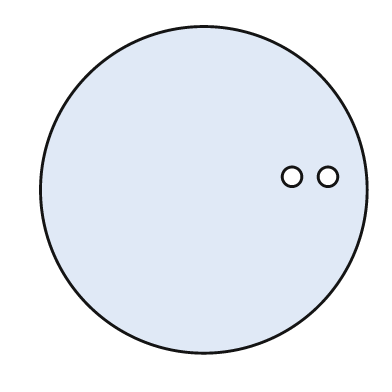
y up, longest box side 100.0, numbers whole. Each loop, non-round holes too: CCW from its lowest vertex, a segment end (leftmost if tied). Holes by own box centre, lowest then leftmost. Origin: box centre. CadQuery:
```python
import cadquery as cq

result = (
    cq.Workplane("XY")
    .moveTo(0.0, 0.0)
    .circle(50.0)
    .moveTo(27.0, 4.0)
    .circle(3.0)
    .moveTo(38.0, 4.0)
    .circle(3.0)
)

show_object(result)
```